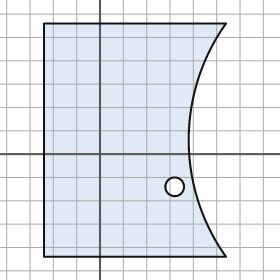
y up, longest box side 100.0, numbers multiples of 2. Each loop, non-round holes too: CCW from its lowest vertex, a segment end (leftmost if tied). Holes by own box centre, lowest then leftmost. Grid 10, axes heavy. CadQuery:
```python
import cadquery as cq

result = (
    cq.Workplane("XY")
    .moveTo(-24.0, -44.0)
    .lineTo(54.0, -44.0)
    .threePointArc((38.0, 6.0), (54.0, 56.0))
    .lineTo(-24.0, 56.0)
    .close()
    .moveTo(32.0, -14.0)
    .circle(4.0)
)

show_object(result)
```